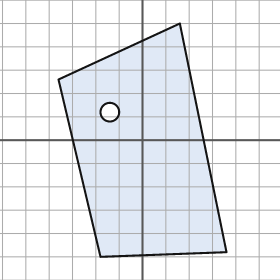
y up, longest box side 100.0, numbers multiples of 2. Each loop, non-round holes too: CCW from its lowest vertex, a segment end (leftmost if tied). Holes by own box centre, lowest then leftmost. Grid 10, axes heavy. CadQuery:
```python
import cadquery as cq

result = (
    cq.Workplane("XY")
    .moveTo(-18.0, -50.0)
    .lineTo(36.0, -48.0)
    .lineTo(16.0, 50.0)
    .lineTo(-36.0, 26.0)
    .close()
    .moveTo(-14.0, 12.0)
    .circle(4.0)
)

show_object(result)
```